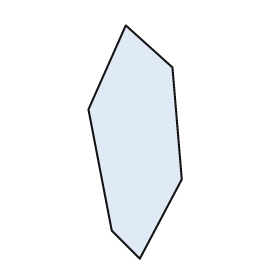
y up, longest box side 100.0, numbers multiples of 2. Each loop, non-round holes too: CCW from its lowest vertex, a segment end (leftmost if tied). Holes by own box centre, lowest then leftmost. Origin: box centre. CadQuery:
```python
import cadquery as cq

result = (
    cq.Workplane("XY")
    .moveTo(2.0, -50.0)
    .lineTo(20.0, -16.0)
    .lineTo(16.0, 32.0)
    .lineTo(-4.0, 50.0)
    .lineTo(-20.0, 14.0)
    .lineTo(-10.0, -38.0)
    .close()
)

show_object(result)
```